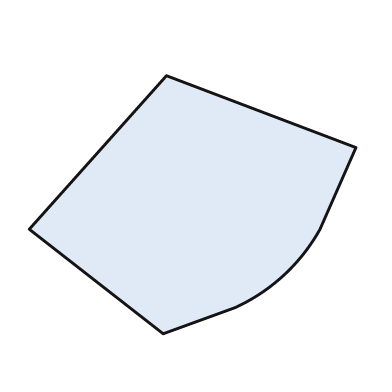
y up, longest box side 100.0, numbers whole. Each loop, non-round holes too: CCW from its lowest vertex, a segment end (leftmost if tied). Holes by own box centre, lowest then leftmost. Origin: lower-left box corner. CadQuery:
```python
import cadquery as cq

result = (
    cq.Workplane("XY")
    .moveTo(41.0, 0.0)
    .lineTo(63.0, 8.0)
    .threePointArc((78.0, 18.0), (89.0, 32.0))
    .lineTo(100.0, 57.0)
    .lineTo(42.0, 79.0)
    .lineTo(0.0, 32.0)
    .close()
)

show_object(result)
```